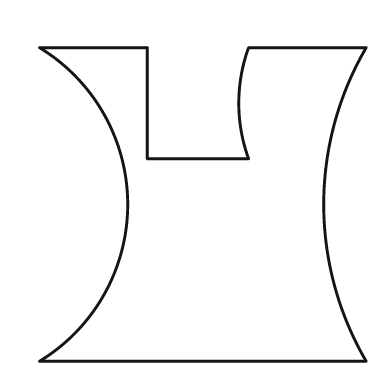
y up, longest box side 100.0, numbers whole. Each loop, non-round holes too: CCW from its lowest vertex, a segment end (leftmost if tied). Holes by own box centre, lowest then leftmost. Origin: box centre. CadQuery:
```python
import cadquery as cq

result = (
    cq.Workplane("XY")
    .moveTo(-50.0, -48.0)
    .lineTo(50.0, -48.0)
    .threePointArc((37.0, 0.0), (50.0, 48.0))
    .lineTo(14.0, 48.0)
    .threePointArc((11.0, 31.0), (14.0, 14.0))
    .lineTo(-17.0, 14.0)
    .lineTo(-17.0, 48.0)
    .lineTo(-50.0, 48.0)
    .threePointArc((-23.0, 0.0), (-50.0, -48.0))
    .close()
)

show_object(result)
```